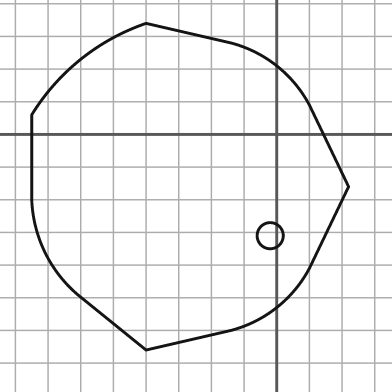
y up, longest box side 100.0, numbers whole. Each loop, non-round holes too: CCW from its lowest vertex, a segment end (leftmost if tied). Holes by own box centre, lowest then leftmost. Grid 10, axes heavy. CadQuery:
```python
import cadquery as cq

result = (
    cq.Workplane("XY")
    .moveTo(-40.0, -66.0)
    .lineTo(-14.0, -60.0)
    .threePointArc((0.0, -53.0), (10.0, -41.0))
    .lineTo(22.0, -16.0)
    .lineTo(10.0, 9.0)
    .threePointArc((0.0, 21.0), (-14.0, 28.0))
    .lineTo(-40.0, 34.0)
    .threePointArc((-60.0, 23.0), (-75.0, 6.0))
    .lineTo(-75.0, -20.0)
    .threePointArc((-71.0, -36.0), (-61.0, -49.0))
    .close()
    .moveTo(-2.0, -31.0)
    .circle(4.0)
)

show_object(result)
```